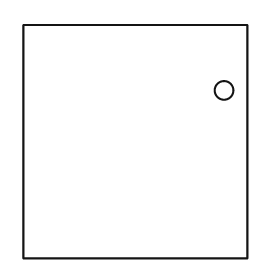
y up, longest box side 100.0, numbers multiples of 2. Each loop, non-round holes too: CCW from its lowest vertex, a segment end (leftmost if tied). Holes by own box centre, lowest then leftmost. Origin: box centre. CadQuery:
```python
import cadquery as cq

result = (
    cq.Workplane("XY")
    .moveTo(-48.0, -50.0)
    .lineTo(48.0, -50.0)
    .lineTo(48.0, 50.0)
    .lineTo(-48.0, 50.0)
    .close()
    .moveTo(38.0, 22.0)
    .circle(4.0)
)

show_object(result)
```